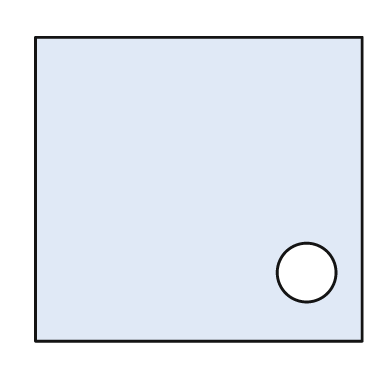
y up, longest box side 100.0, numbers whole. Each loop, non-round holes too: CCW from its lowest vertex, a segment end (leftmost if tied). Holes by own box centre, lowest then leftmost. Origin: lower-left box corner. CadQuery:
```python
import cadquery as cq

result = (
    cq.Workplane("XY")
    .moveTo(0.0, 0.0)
    .lineTo(100.0, 0.0)
    .lineTo(100.0, 93.0)
    .lineTo(0.0, 93.0)
    .close()
    .moveTo(83.0, 21.0)
    .circle(9.0)
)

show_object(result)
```